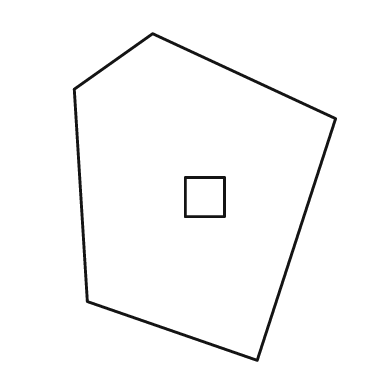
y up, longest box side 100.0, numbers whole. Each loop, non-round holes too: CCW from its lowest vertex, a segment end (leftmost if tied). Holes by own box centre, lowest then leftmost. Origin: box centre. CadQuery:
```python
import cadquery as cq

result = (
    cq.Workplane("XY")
    .moveTo(16.0, -50.0)
    .lineTo(40.0, 24.0)
    .lineTo(-16.0, 50.0)
    .lineTo(-40.0, 33.0)
    .lineTo(-36.0, -32.0)
    .close()
    .moveTo(-6.0, -6.0)
    .lineTo(6.0, -6.0)
    .lineTo(6.0, 6.0)
    .lineTo(-6.0, 6.0)
    .close()
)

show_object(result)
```